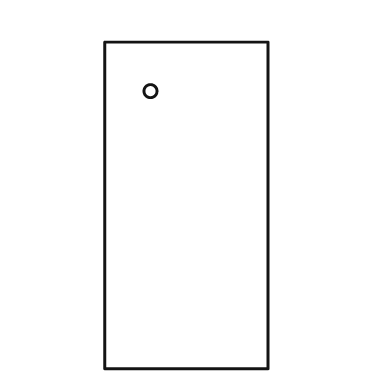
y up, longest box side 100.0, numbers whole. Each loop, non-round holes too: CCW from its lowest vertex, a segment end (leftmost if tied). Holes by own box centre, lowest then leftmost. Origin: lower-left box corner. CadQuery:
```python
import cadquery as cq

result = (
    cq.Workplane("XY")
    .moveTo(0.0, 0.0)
    .lineTo(50.0, 0.0)
    .lineTo(50.0, 100.0)
    .lineTo(0.0, 100.0)
    .close()
    .moveTo(14.0, 85.0)
    .circle(2.0)
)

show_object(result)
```